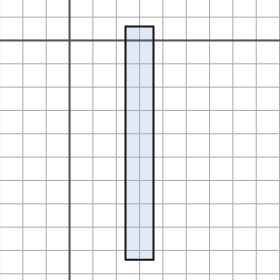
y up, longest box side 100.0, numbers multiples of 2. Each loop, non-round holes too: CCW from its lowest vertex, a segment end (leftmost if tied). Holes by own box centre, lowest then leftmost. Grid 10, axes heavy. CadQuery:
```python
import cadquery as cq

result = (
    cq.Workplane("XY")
    .moveTo(24.0, -94.0)
    .lineTo(36.0, -94.0)
    .lineTo(36.0, 6.0)
    .lineTo(24.0, 6.0)
    .close()
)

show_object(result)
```